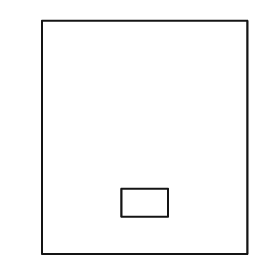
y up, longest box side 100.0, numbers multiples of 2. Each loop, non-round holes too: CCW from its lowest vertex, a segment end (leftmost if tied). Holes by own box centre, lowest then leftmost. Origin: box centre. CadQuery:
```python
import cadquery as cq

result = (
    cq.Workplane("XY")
    .moveTo(-44.0, -50.0)
    .lineTo(44.0, -50.0)
    .lineTo(44.0, 50.0)
    .lineTo(-44.0, 50.0)
    .close()
    .moveTo(-10.0, -34.0)
    .lineTo(10.0, -34.0)
    .lineTo(10.0, -22.0)
    .lineTo(-10.0, -22.0)
    .close()
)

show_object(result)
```